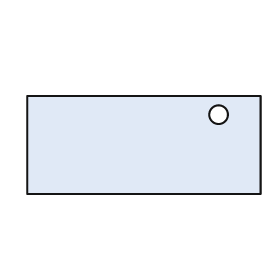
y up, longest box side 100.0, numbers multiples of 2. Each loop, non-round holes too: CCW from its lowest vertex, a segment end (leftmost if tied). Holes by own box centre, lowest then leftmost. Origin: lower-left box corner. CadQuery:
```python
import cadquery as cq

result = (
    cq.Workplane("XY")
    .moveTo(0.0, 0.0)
    .lineTo(100.0, 0.0)
    .lineTo(100.0, 42.0)
    .lineTo(0.0, 42.0)
    .close()
    .moveTo(82.0, 34.0)
    .circle(4.0)
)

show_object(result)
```